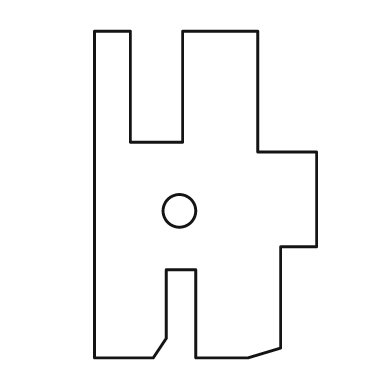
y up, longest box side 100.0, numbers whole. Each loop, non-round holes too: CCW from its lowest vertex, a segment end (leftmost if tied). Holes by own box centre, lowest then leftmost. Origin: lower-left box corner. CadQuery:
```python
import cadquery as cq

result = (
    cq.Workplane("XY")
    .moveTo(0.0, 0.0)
    .lineTo(18.0, 0.0)
    .lineTo(22.0, 6.0)
    .lineTo(22.0, 27.0)
    .lineTo(31.0, 27.0)
    .lineTo(31.0, 0.0)
    .lineTo(47.0, 0.0)
    .lineTo(57.0, 3.0)
    .lineTo(57.0, 34.0)
    .lineTo(68.0, 34.0)
    .lineTo(68.0, 63.0)
    .lineTo(50.0, 63.0)
    .lineTo(50.0, 100.0)
    .lineTo(27.0, 100.0)
    .lineTo(27.0, 66.0)
    .lineTo(11.0, 66.0)
    .lineTo(11.0, 100.0)
    .lineTo(0.0, 100.0)
    .close()
    .moveTo(26.0, 45.0)
    .circle(5.0)
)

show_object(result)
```